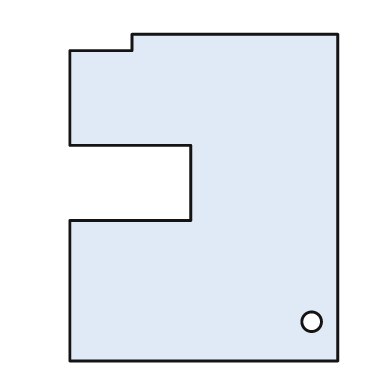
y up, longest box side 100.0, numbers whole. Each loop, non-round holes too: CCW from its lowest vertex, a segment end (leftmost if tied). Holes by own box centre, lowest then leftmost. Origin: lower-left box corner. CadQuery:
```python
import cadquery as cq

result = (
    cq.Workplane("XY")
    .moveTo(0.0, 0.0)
    .lineTo(82.0, 0.0)
    .lineTo(82.0, 100.0)
    .lineTo(19.0, 100.0)
    .lineTo(19.0, 95.0)
    .lineTo(0.0, 95.0)
    .lineTo(0.0, 66.0)
    .lineTo(37.0, 66.0)
    .lineTo(37.0, 43.0)
    .lineTo(0.0, 43.0)
    .close()
    .moveTo(74.0, 12.0)
    .circle(3.0)
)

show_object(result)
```